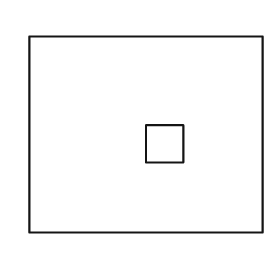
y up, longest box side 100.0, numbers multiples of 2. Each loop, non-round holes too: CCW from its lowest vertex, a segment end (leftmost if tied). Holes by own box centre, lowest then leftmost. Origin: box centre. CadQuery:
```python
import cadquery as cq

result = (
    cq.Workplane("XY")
    .moveTo(-50.0, -42.0)
    .lineTo(50.0, -42.0)
    .lineTo(50.0, 42.0)
    .lineTo(-50.0, 42.0)
    .close()
    .moveTo(0.0, -12.0)
    .lineTo(16.0, -12.0)
    .lineTo(16.0, 4.0)
    .lineTo(0.0, 4.0)
    .close()
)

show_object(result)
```